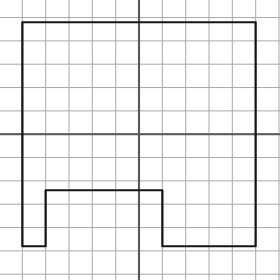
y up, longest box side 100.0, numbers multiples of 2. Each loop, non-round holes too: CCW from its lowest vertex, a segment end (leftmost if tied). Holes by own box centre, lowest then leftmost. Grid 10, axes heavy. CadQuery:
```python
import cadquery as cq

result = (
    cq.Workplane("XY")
    .moveTo(-50.0, -48.0)
    .lineTo(-40.0, -48.0)
    .lineTo(-40.0, -24.0)
    .lineTo(10.0, -24.0)
    .lineTo(10.0, -48.0)
    .lineTo(50.0, -48.0)
    .lineTo(50.0, 48.0)
    .lineTo(-50.0, 48.0)
    .close()
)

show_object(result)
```